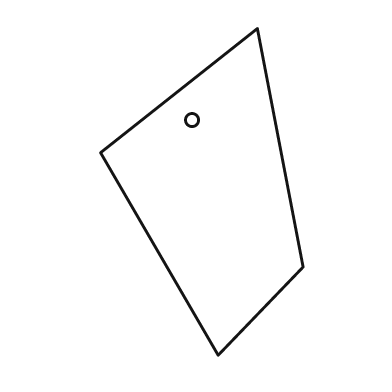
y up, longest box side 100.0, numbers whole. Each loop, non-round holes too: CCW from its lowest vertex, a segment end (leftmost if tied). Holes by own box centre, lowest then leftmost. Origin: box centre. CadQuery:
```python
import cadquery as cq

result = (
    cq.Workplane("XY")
    .moveTo(5.0, -50.0)
    .lineTo(31.0, -23.0)
    .lineTo(17.0, 50.0)
    .lineTo(-31.0, 12.0)
    .close()
    .moveTo(-3.0, 22.0)
    .circle(2.0)
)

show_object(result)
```